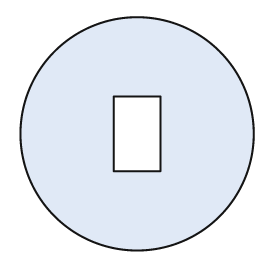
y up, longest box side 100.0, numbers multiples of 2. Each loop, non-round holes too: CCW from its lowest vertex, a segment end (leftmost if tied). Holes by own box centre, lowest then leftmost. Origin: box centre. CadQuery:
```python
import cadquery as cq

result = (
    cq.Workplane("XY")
    .moveTo(0.0, 0.0)
    .circle(50.0)
    .moveTo(-10.0, -16.0)
    .lineTo(10.0, -16.0)
    .lineTo(10.0, 16.0)
    .lineTo(-10.0, 16.0)
    .close()
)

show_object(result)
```